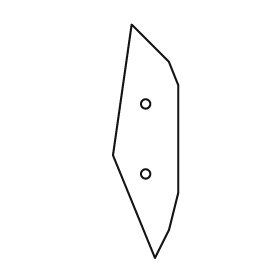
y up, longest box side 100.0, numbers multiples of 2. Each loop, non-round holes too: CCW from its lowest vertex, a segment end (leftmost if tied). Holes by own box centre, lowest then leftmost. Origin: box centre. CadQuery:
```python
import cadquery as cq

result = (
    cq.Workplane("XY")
    .moveTo(4.0, -50.0)
    .lineTo(10.0, -38.0)
    .lineTo(14.0, -22.0)
    .lineTo(14.0, 24.0)
    .lineTo(10.0, 34.0)
    .lineTo(-6.0, 50.0)
    .lineTo(-14.0, -6.0)
    .close()
    .moveTo(0.0, -14.0)
    .circle(2.0)
    .moveTo(0.0, 16.0)
    .circle(2.0)
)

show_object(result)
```